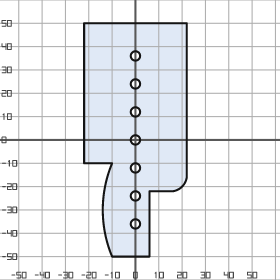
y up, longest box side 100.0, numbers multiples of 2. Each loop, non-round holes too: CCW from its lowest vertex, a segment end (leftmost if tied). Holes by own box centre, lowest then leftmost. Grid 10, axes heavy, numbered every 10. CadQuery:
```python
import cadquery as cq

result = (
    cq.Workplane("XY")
    .moveTo(-10.0, -50.0)
    .lineTo(6.0, -50.0)
    .lineTo(6.0, -22.0)
    .lineTo(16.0, -22.0)
    .threePointArc((20.0, -20.0), (22.0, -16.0))
    .lineTo(22.0, 50.0)
    .lineTo(-22.0, 50.0)
    .lineTo(-22.0, -10.0)
    .lineTo(-10.0, -10.0)
    .threePointArc((-14.0, -30.0), (-10.0, -50.0))
    .close()
    .moveTo(0.0, -36.0)
    .circle(2.0)
    .moveTo(0.0, -24.0)
    .circle(2.0)
    .moveTo(0.0, -12.0)
    .circle(2.0)
    .moveTo(0.0, 0.0)
    .circle(2.0)
    .moveTo(0.0, 12.0)
    .circle(2.0)
    .moveTo(0.0, 24.0)
    .circle(2.0)
    .moveTo(0.0, 36.0)
    .circle(2.0)
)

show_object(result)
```